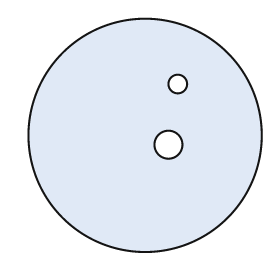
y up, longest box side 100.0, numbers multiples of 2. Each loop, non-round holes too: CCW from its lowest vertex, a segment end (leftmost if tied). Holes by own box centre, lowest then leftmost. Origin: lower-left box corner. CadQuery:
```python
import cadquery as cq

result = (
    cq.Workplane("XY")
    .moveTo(50.0, 50.0)
    .circle(50.0)
    .moveTo(60.0, 46.0)
    .circle(6.0)
    .moveTo(64.0, 72.0)
    .circle(4.0)
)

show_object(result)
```